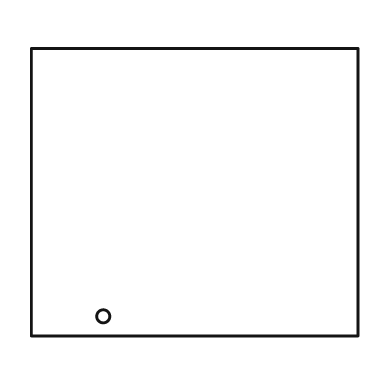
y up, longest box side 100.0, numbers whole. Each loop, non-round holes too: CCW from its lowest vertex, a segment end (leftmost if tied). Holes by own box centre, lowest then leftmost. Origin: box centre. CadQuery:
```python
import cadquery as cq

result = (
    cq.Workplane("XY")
    .moveTo(-50.0, -44.0)
    .lineTo(50.0, -44.0)
    .lineTo(50.0, 44.0)
    .lineTo(-50.0, 44.0)
    .close()
    .moveTo(-28.0, -38.0)
    .circle(2.0)
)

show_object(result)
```